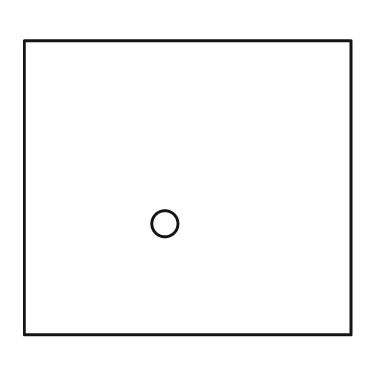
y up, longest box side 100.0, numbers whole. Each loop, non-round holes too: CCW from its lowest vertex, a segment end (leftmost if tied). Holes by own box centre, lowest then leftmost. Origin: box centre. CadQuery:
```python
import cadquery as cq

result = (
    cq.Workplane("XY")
    .moveTo(-50.0, -45.0)
    .lineTo(50.0, -45.0)
    .lineTo(50.0, 45.0)
    .lineTo(-50.0, 45.0)
    .close()
    .moveTo(-7.0, -11.0)
    .circle(4.0)
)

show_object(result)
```